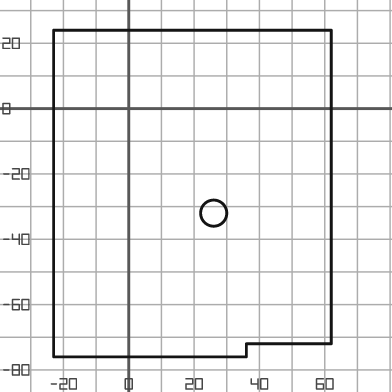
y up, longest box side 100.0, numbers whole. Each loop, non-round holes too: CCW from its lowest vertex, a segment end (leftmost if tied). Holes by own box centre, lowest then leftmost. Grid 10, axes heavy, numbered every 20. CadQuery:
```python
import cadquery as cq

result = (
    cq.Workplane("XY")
    .moveTo(-23.0, -76.0)
    .lineTo(36.0, -76.0)
    .lineTo(36.0, -72.0)
    .lineTo(62.0, -72.0)
    .lineTo(62.0, 24.0)
    .lineTo(-23.0, 24.0)
    .close()
    .moveTo(26.0, -32.0)
    .circle(4.0)
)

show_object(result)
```